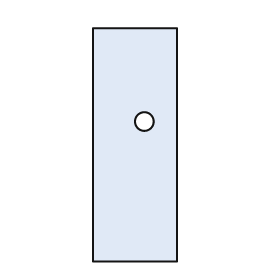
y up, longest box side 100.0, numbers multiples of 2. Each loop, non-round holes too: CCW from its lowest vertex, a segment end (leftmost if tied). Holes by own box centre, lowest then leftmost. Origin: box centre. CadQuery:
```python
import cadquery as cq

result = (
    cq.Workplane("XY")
    .moveTo(-18.0, -50.0)
    .lineTo(18.0, -50.0)
    .lineTo(18.0, 50.0)
    .lineTo(-18.0, 50.0)
    .close()
    .moveTo(4.0, 10.0)
    .circle(4.0)
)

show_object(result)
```